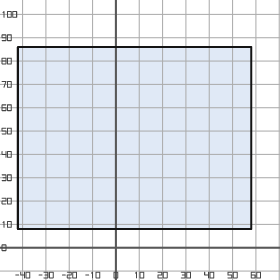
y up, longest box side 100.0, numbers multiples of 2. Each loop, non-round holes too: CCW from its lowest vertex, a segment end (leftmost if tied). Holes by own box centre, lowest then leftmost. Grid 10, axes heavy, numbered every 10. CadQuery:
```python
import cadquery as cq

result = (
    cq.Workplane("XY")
    .moveTo(-42.0, 8.0)
    .lineTo(58.0, 8.0)
    .lineTo(58.0, 86.0)
    .lineTo(-42.0, 86.0)
    .close()
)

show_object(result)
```